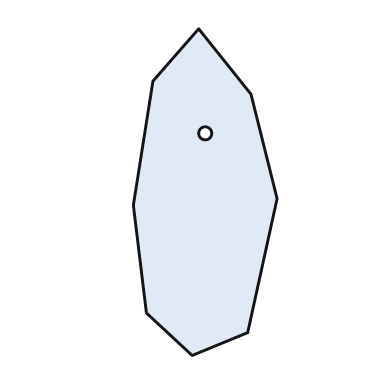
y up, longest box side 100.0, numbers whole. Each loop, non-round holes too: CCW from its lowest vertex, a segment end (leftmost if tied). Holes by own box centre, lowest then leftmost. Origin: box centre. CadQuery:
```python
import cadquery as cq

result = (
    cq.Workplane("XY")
    .moveTo(-4.0, -50.0)
    .lineTo(13.0, -43.0)
    .lineTo(22.0, -2.0)
    .lineTo(14.0, 30.0)
    .lineTo(-2.0, 50.0)
    .lineTo(-16.0, 34.0)
    .lineTo(-22.0, -4.0)
    .lineTo(-18.0, -37.0)
    .close()
    .moveTo(0.0, 18.0)
    .circle(2.0)
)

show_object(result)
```